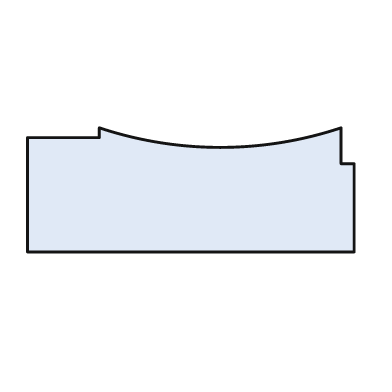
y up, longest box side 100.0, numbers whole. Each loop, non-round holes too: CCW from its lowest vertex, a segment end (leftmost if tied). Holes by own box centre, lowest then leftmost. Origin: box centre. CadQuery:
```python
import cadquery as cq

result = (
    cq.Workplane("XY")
    .moveTo(-50.0, -19.0)
    .lineTo(50.0, -19.0)
    .lineTo(50.0, 8.0)
    .lineTo(46.0, 8.0)
    .lineTo(46.0, 19.0)
    .threePointArc((9.0, 13.0), (-28.0, 19.0))
    .lineTo(-28.0, 16.0)
    .lineTo(-50.0, 16.0)
    .close()
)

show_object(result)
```